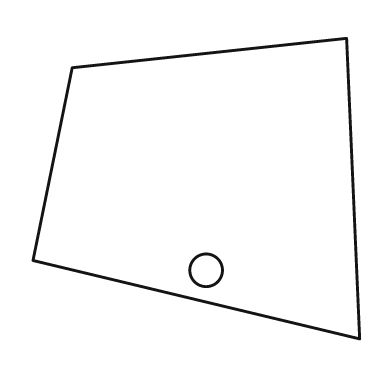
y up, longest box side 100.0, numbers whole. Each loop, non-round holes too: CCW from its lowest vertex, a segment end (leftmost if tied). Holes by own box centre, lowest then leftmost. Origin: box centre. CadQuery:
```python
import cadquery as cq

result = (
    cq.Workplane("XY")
    .moveTo(50.0, -46.0)
    .lineTo(46.0, 46.0)
    .lineTo(-38.0, 37.0)
    .lineTo(-50.0, -22.0)
    .close()
    .moveTo(3.0, -25.0)
    .circle(5.0)
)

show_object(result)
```